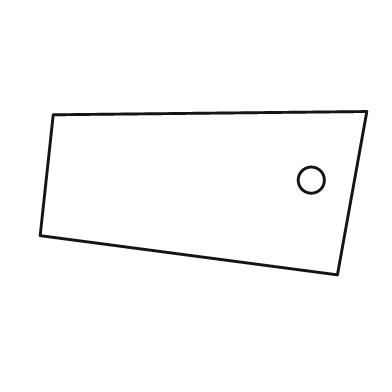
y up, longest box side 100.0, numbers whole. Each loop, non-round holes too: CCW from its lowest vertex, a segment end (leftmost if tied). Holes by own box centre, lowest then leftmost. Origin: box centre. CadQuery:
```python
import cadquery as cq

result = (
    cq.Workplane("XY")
    .moveTo(41.0, -25.0)
    .lineTo(50.0, 25.0)
    .lineTo(-46.0, 24.0)
    .lineTo(-50.0, -13.0)
    .close()
    .moveTo(33.0, 4.0)
    .circle(4.0)
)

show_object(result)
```